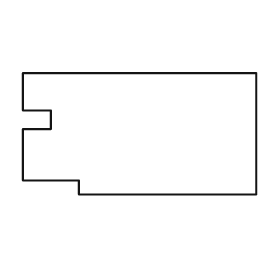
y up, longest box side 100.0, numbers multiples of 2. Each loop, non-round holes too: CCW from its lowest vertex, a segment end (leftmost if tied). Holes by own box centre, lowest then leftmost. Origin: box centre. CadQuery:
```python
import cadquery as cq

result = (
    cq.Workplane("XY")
    .moveTo(-26.0, -26.0)
    .lineTo(50.0, -26.0)
    .lineTo(50.0, 26.0)
    .lineTo(-50.0, 26.0)
    .lineTo(-50.0, 10.0)
    .lineTo(-38.0, 10.0)
    .lineTo(-38.0, 2.0)
    .lineTo(-50.0, 2.0)
    .lineTo(-50.0, -20.0)
    .lineTo(-26.0, -20.0)
    .close()
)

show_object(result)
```